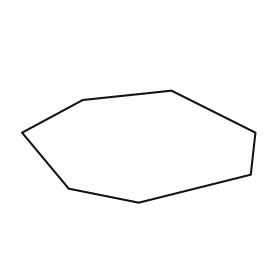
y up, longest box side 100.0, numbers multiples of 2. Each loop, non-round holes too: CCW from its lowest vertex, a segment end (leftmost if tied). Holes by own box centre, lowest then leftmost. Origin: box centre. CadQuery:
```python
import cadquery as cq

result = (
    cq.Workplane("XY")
    .moveTo(0.0, -24.0)
    .lineTo(48.0, -12.0)
    .lineTo(50.0, 6.0)
    .lineTo(14.0, 24.0)
    .lineTo(-24.0, 20.0)
    .lineTo(-50.0, 6.0)
    .lineTo(-30.0, -18.0)
    .close()
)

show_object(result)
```